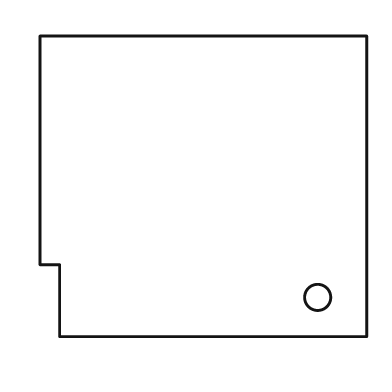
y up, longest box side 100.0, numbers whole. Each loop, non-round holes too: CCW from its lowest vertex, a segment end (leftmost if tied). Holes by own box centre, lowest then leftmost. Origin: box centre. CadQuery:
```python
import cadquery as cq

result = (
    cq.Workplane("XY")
    .moveTo(-44.0, -46.0)
    .lineTo(50.0, -46.0)
    .lineTo(50.0, 46.0)
    .lineTo(-50.0, 46.0)
    .lineTo(-50.0, -24.0)
    .lineTo(-44.0, -24.0)
    .close()
    .moveTo(35.0, -34.0)
    .circle(4.0)
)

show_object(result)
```